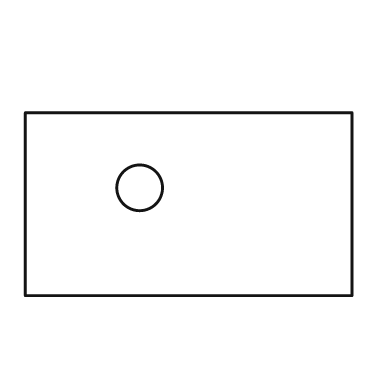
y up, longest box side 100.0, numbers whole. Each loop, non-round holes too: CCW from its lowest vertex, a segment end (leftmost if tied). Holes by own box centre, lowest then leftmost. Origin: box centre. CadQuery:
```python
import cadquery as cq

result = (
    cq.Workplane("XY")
    .moveTo(-50.0, -28.0)
    .lineTo(50.0, -28.0)
    .lineTo(50.0, 28.0)
    .lineTo(-50.0, 28.0)
    .close()
    .moveTo(-15.0, 5.0)
    .circle(7.0)
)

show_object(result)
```